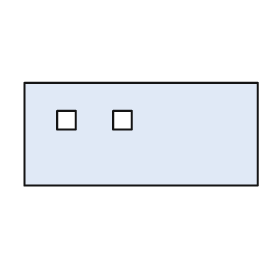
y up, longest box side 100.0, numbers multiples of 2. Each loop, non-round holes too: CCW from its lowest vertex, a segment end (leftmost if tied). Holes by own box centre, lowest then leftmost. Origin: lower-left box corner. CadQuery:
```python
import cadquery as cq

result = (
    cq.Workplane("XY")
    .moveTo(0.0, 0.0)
    .lineTo(100.0, 0.0)
    .lineTo(100.0, 44.0)
    .lineTo(0.0, 44.0)
    .close()
    .moveTo(14.0, 24.0)
    .lineTo(22.0, 24.0)
    .lineTo(22.0, 32.0)
    .lineTo(14.0, 32.0)
    .close()
    .moveTo(38.0, 24.0)
    .lineTo(46.0, 24.0)
    .lineTo(46.0, 32.0)
    .lineTo(38.0, 32.0)
    .close()
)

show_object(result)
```